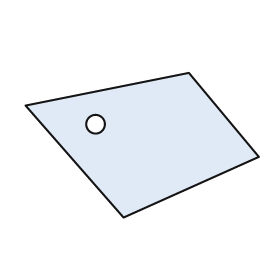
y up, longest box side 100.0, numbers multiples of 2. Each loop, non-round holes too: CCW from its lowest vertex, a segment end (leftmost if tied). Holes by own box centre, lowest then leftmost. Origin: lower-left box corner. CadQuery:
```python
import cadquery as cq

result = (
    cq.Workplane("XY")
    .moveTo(42.0, 0.0)
    .lineTo(100.0, 26.0)
    .lineTo(70.0, 62.0)
    .lineTo(0.0, 48.0)
    .close()
    .moveTo(30.0, 40.0)
    .circle(4.0)
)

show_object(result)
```